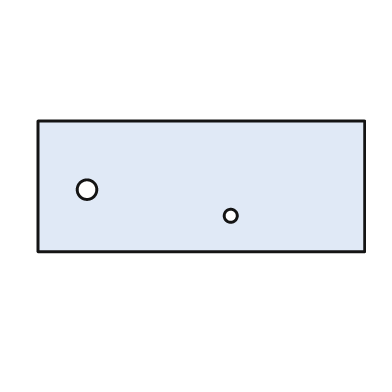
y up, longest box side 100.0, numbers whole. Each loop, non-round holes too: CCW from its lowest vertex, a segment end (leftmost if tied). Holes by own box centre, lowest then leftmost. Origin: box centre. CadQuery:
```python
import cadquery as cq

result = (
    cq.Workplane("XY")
    .moveTo(-50.0, -20.0)
    .lineTo(50.0, -20.0)
    .lineTo(50.0, 20.0)
    .lineTo(-50.0, 20.0)
    .close()
    .moveTo(9.0, -9.0)
    .circle(2.0)
    .moveTo(-35.0, -1.0)
    .circle(3.0)
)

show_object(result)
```